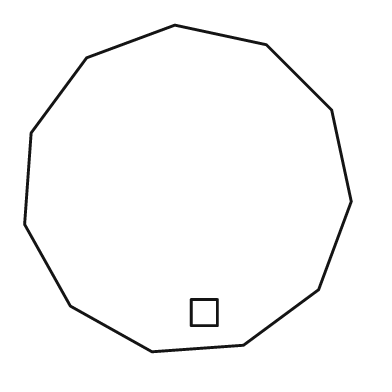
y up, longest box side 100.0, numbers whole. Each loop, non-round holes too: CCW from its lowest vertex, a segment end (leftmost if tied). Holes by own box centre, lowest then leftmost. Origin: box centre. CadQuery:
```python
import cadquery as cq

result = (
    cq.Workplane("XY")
    .moveTo(-11.0, -50.0)
    .lineTo(17.0, -48.0)
    .lineTo(40.0, -31.0)
    .lineTo(50.0, -4.0)
    .lineTo(44.0, 24.0)
    .lineTo(24.0, 44.0)
    .lineTo(-4.0, 50.0)
    .lineTo(-31.0, 40.0)
    .lineTo(-48.0, 17.0)
    .lineTo(-50.0, -11.0)
    .lineTo(-36.0, -36.0)
    .close()
    .moveTo(1.0, -42.0)
    .lineTo(9.0, -42.0)
    .lineTo(9.0, -34.0)
    .lineTo(1.0, -34.0)
    .close()
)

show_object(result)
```